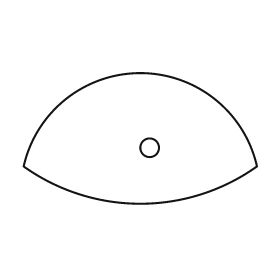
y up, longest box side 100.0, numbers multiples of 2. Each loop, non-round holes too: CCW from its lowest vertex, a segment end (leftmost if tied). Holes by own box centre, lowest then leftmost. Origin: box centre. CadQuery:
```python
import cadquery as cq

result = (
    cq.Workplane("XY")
    .moveTo(-50.0, -12.0)
    .threePointArc((0.0, -28.0), (50.0, -12.0))
    .threePointArc((0.0, 28.0), (-50.0, -12.0))
    .close()
    .moveTo(4.0, -4.0)
    .circle(4.0)
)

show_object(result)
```